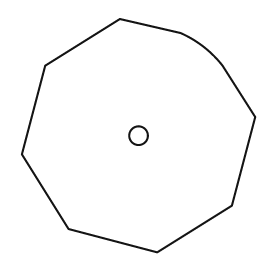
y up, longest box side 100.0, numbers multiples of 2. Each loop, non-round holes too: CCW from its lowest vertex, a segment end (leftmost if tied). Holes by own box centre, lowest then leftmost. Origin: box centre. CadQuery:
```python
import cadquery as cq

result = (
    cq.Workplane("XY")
    .moveTo(8.0, -50.0)
    .lineTo(40.0, -30.0)
    .lineTo(50.0, 8.0)
    .lineTo(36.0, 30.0)
    .threePointArc((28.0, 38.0), (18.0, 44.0))
    .lineTo(-8.0, 50.0)
    .lineTo(-40.0, 30.0)
    .lineTo(-50.0, -8.0)
    .lineTo(-30.0, -40.0)
    .close()
    .moveTo(0.0, 0.0)
    .circle(4.0)
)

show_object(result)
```